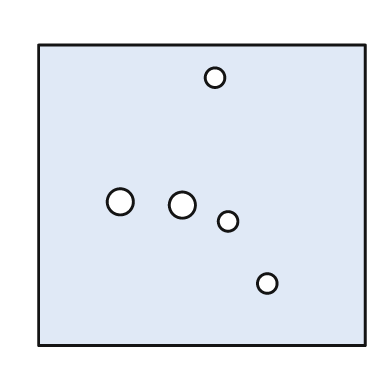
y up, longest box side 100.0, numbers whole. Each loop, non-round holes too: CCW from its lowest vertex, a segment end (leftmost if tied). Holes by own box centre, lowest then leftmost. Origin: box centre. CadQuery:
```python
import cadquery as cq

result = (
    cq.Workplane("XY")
    .moveTo(-50.0, -46.0)
    .lineTo(50.0, -46.0)
    .lineTo(50.0, 46.0)
    .lineTo(-50.0, 46.0)
    .close()
    .moveTo(20.0, -27.0)
    .circle(3.0)
    .moveTo(8.0, -8.0)
    .circle(3.0)
    .moveTo(-6.0, -3.0)
    .circle(4.0)
    .moveTo(-25.0, -2.0)
    .circle(4.0)
    .moveTo(4.0, 36.0)
    .circle(3.0)
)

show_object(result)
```